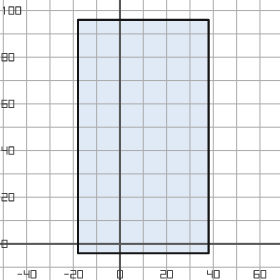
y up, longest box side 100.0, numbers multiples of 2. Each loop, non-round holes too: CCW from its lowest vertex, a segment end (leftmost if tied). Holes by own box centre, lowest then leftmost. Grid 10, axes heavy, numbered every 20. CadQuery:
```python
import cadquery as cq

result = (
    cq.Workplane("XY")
    .moveTo(-18.0, -4.0)
    .lineTo(38.0, -4.0)
    .lineTo(38.0, 96.0)
    .lineTo(-18.0, 96.0)
    .close()
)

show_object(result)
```